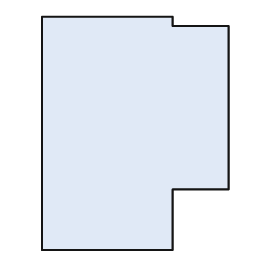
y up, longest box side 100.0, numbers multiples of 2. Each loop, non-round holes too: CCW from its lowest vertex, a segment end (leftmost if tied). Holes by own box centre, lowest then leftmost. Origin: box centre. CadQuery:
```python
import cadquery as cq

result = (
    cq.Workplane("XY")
    .moveTo(-40.0, -50.0)
    .lineTo(16.0, -50.0)
    .lineTo(16.0, -24.0)
    .lineTo(40.0, -24.0)
    .lineTo(40.0, 46.0)
    .lineTo(16.0, 46.0)
    .lineTo(16.0, 50.0)
    .lineTo(-40.0, 50.0)
    .close()
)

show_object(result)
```